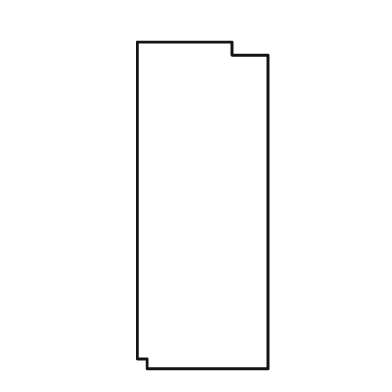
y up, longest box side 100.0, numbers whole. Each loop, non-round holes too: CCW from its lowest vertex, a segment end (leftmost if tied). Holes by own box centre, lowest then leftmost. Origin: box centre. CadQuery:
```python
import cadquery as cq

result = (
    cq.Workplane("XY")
    .moveTo(-17.0, -50.0)
    .lineTo(20.0, -50.0)
    .lineTo(20.0, 46.0)
    .lineTo(9.0, 46.0)
    .lineTo(9.0, 50.0)
    .lineTo(-20.0, 50.0)
    .lineTo(-20.0, -47.0)
    .lineTo(-17.0, -47.0)
    .close()
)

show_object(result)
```